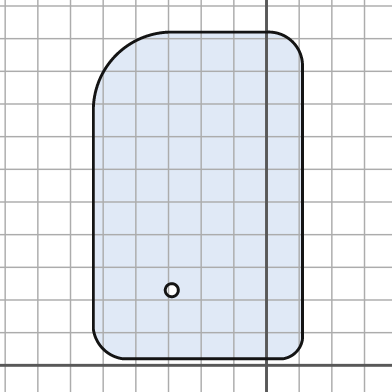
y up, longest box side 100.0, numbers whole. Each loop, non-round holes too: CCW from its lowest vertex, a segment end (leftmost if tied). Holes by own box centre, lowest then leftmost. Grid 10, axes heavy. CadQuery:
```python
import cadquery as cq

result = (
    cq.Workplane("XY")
    .moveTo(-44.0, 2.0)
    .lineTo(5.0, 2.0)
    .threePointArc((9.0, 4.0), (11.0, 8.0))
    .lineTo(11.0, 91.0)
    .threePointArc((8.0, 99.0), (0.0, 102.0))
    .lineTo(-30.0, 102.0)
    .threePointArc((-46.0, 95.0), (-53.0, 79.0))
    .lineTo(-53.0, 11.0)
    .threePointArc((-50.0, 5.0), (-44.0, 2.0))
    .close()
    .moveTo(-29.0, 23.0)
    .circle(2.0)
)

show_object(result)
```